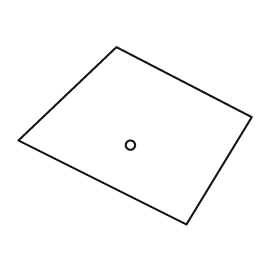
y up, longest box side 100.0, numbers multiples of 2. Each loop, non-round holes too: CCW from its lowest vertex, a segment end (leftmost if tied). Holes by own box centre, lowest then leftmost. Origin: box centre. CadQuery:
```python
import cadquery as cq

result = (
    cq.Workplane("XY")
    .moveTo(22.0, -38.0)
    .lineTo(50.0, 8.0)
    .lineTo(-8.0, 38.0)
    .lineTo(-50.0, -2.0)
    .close()
    .moveTo(-2.0, -4.0)
    .circle(2.0)
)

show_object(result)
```